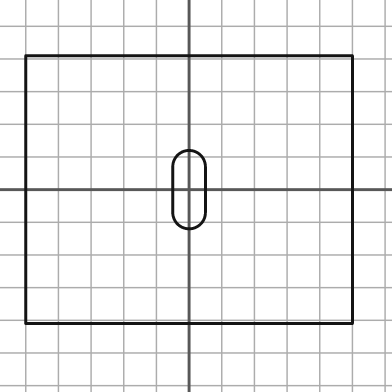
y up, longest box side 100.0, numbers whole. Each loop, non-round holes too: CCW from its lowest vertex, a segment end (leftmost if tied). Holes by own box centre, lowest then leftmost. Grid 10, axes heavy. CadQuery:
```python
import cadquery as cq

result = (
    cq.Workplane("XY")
    .moveTo(-50.0, -41.0)
    .lineTo(50.0, -41.0)
    .lineTo(50.0, 41.0)
    .lineTo(-50.0, 41.0)
    .close()
    .moveTo(-5.0, -7.0)
    .threePointArc((0.0, -12.0), (5.0, -7.0))
    .lineTo(5.0, 7.0)
    .threePointArc((0.0, 12.0), (-5.0, 7.0))
    .close()
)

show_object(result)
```